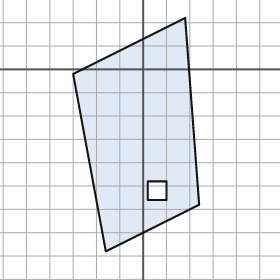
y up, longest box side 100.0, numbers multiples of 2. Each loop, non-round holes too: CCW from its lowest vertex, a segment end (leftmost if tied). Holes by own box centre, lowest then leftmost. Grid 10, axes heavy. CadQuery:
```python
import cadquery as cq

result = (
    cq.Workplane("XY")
    .moveTo(-16.0, -78.0)
    .lineTo(24.0, -58.0)
    .lineTo(18.0, 22.0)
    .lineTo(-30.0, -2.0)
    .close()
    .moveTo(2.0, -56.0)
    .lineTo(10.0, -56.0)
    .lineTo(10.0, -48.0)
    .lineTo(2.0, -48.0)
    .close()
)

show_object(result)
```